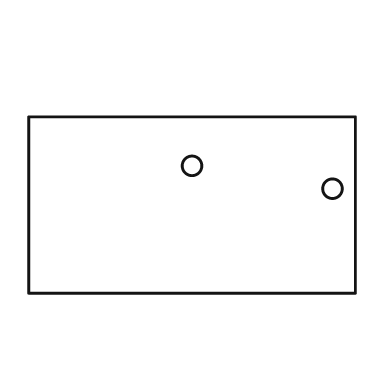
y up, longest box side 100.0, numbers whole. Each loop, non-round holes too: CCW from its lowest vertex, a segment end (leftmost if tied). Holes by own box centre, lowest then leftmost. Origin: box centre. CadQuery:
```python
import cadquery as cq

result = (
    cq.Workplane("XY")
    .moveTo(-50.0, -27.0)
    .lineTo(50.0, -27.0)
    .lineTo(50.0, 27.0)
    .lineTo(-50.0, 27.0)
    .close()
    .moveTo(43.0, 5.0)
    .circle(3.0)
    .moveTo(0.0, 12.0)
    .circle(3.0)
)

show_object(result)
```